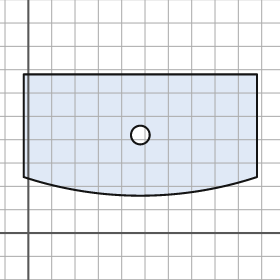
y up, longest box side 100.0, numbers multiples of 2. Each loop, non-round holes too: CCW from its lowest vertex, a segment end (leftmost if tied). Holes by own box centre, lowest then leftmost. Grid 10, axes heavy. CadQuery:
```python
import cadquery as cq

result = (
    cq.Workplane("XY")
    .moveTo(-2.0, 24.0)
    .threePointArc((48.0, 16.0), (98.0, 24.0))
    .lineTo(98.0, 68.0)
    .lineTo(-2.0, 68.0)
    .close()
    .moveTo(48.0, 42.0)
    .circle(4.0)
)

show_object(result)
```